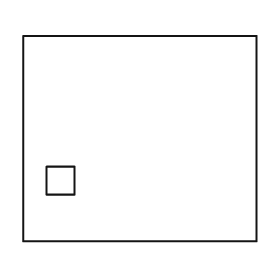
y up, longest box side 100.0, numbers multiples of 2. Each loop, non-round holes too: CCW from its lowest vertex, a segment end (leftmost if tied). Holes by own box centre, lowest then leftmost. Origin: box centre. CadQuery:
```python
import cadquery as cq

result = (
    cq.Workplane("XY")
    .moveTo(-50.0, -44.0)
    .lineTo(50.0, -44.0)
    .lineTo(50.0, 44.0)
    .lineTo(-50.0, 44.0)
    .close()
    .moveTo(-40.0, -24.0)
    .lineTo(-28.0, -24.0)
    .lineTo(-28.0, -12.0)
    .lineTo(-40.0, -12.0)
    .close()
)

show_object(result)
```